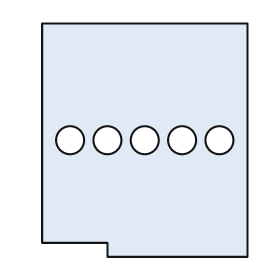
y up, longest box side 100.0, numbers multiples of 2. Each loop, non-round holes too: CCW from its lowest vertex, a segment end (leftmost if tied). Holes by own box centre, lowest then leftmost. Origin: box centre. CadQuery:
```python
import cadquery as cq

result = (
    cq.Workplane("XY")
    .moveTo(-16.0, -50.0)
    .lineTo(44.0, -50.0)
    .lineTo(44.0, 50.0)
    .lineTo(-44.0, 50.0)
    .lineTo(-44.0, -44.0)
    .lineTo(-16.0, -44.0)
    .close()
    .moveTo(-32.0, 0.0)
    .circle(6.0)
    .moveTo(-16.0, 0.0)
    .circle(6.0)
    .moveTo(0.0, 0.0)
    .circle(6.0)
    .moveTo(16.0, 0.0)
    .circle(6.0)
    .moveTo(32.0, 0.0)
    .circle(6.0)
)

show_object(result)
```